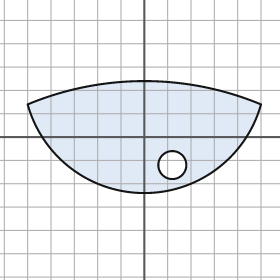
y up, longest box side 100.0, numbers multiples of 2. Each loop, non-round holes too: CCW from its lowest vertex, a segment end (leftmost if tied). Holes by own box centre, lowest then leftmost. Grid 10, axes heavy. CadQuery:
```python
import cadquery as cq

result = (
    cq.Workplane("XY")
    .moveTo(-50.0, 14.0)
    .threePointArc((0.0, -24.0), (50.0, 14.0))
    .threePointArc((0.0, 24.0), (-50.0, 14.0))
    .close()
    .moveTo(12.0, -12.0)
    .circle(6.0)
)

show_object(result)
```